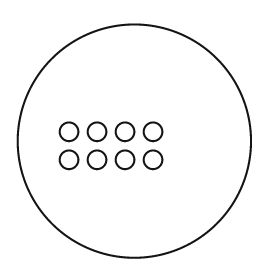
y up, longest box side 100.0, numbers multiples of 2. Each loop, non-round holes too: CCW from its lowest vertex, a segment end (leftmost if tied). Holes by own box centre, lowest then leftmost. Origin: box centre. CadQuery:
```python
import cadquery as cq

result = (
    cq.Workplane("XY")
    .moveTo(0.0, 0.0)
    .circle(50.0)
    .moveTo(-28.0, -8.0)
    .circle(4.0)
    .moveTo(-16.0, -8.0)
    .circle(4.0)
    .moveTo(-4.0, -8.0)
    .circle(4.0)
    .moveTo(8.0, -8.0)
    .circle(4.0)
    .moveTo(-28.0, 4.0)
    .circle(4.0)
    .moveTo(-16.0, 4.0)
    .circle(4.0)
    .moveTo(-4.0, 4.0)
    .circle(4.0)
    .moveTo(8.0, 4.0)
    .circle(4.0)
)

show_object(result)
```